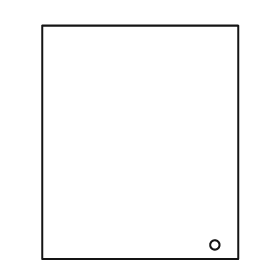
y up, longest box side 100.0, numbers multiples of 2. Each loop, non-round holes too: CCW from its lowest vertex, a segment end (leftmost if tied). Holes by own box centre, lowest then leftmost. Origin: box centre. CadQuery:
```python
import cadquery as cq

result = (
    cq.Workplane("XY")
    .moveTo(-42.0, -50.0)
    .lineTo(42.0, -50.0)
    .lineTo(42.0, 50.0)
    .lineTo(-42.0, 50.0)
    .close()
    .moveTo(32.0, -44.0)
    .circle(2.0)
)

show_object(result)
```